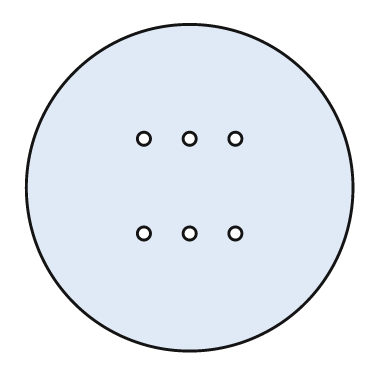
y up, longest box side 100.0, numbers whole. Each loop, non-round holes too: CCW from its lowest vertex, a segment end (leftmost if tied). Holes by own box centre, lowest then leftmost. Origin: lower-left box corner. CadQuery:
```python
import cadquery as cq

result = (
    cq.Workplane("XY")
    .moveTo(50.0, 50.0)
    .circle(50.0)
    .moveTo(36.0, 36.0)
    .circle(2.0)
    .moveTo(50.0, 36.0)
    .circle(2.0)
    .moveTo(64.0, 36.0)
    .circle(2.0)
    .moveTo(36.0, 65.0)
    .circle(2.0)
    .moveTo(50.0, 65.0)
    .circle(2.0)
    .moveTo(64.0, 65.0)
    .circle(2.0)
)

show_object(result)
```